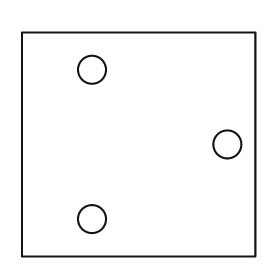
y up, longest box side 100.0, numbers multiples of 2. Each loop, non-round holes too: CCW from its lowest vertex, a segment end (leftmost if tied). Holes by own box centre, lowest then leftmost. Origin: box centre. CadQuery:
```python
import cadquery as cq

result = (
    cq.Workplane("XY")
    .moveTo(-50.0, -48.0)
    .lineTo(50.0, -48.0)
    .lineTo(50.0, 48.0)
    .lineTo(-50.0, 48.0)
    .close()
    .moveTo(-20.0, -32.0)
    .circle(6.0)
    .moveTo(38.0, 0.0)
    .circle(6.0)
    .moveTo(-20.0, 32.0)
    .circle(6.0)
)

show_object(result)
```